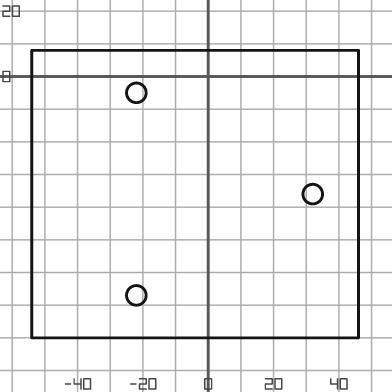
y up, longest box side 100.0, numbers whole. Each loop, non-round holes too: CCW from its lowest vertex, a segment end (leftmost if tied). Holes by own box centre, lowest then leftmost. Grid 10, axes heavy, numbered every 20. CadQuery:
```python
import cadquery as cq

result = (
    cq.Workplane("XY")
    .moveTo(-54.0, -80.0)
    .lineTo(46.0, -80.0)
    .lineTo(46.0, 8.0)
    .lineTo(-54.0, 8.0)
    .close()
    .moveTo(-22.0, -67.0)
    .circle(3.0)
    .moveTo(32.0, -36.0)
    .circle(3.0)
    .moveTo(-22.0, -5.0)
    .circle(3.0)
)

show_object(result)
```